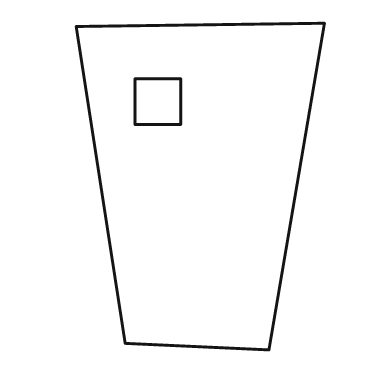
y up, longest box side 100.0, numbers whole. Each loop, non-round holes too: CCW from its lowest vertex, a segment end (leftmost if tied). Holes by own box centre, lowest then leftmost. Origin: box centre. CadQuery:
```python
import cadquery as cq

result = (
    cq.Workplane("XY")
    .moveTo(21.0, -50.0)
    .lineTo(38.0, 50.0)
    .lineTo(-38.0, 49.0)
    .lineTo(-23.0, -48.0)
    .close()
    .moveTo(-20.0, 19.0)
    .lineTo(-6.0, 19.0)
    .lineTo(-6.0, 33.0)
    .lineTo(-20.0, 33.0)
    .close()
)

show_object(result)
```